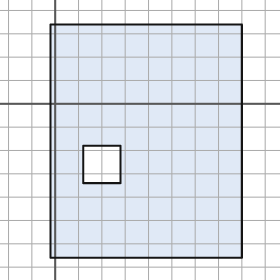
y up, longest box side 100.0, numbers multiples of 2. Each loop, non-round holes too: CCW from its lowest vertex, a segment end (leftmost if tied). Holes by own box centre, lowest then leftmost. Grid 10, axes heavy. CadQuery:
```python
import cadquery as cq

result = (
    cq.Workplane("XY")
    .moveTo(-2.0, -66.0)
    .lineTo(80.0, -66.0)
    .lineTo(80.0, 34.0)
    .lineTo(-2.0, 34.0)
    .close()
    .moveTo(12.0, -34.0)
    .lineTo(28.0, -34.0)
    .lineTo(28.0, -18.0)
    .lineTo(12.0, -18.0)
    .close()
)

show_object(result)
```